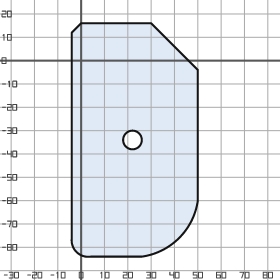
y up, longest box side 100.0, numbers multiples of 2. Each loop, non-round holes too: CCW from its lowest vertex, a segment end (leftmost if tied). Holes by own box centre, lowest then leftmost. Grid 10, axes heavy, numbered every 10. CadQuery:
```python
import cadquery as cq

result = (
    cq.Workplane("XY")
    .moveTo(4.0, -84.0)
    .lineTo(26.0, -84.0)
    .threePointArc((42.0, -76.0), (50.0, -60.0))
    .lineTo(50.0, -4.0)
    .lineTo(30.0, 16.0)
    .lineTo(0.0, 16.0)
    .lineTo(-4.0, 12.0)
    .lineTo(-4.0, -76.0)
    .threePointArc((-2.0, -82.0), (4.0, -84.0))
    .close()
    .moveTo(22.0, -34.0)
    .circle(4.0)
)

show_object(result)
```